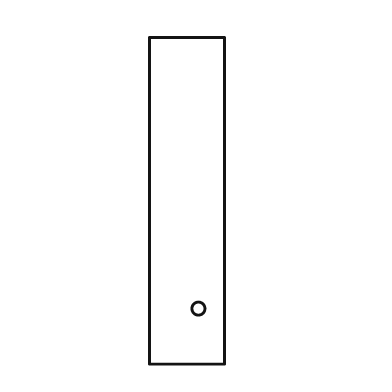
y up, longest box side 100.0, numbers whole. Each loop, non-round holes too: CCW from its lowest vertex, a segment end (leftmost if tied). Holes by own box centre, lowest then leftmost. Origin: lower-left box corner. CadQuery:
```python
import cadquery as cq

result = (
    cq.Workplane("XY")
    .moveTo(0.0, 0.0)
    .lineTo(23.0, 0.0)
    .lineTo(23.0, 100.0)
    .lineTo(0.0, 100.0)
    .close()
    .moveTo(15.0, 17.0)
    .circle(2.0)
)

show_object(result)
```